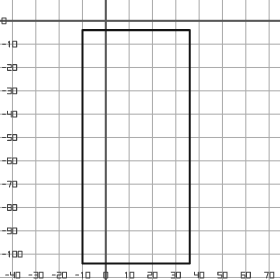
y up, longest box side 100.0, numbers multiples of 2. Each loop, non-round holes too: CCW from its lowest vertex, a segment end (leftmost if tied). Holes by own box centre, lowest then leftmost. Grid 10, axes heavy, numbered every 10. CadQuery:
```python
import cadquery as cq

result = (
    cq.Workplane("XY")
    .moveTo(-10.0, -104.0)
    .lineTo(36.0, -104.0)
    .lineTo(36.0, -4.0)
    .lineTo(-10.0, -4.0)
    .close()
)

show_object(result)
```